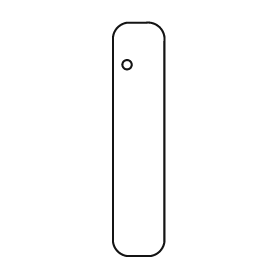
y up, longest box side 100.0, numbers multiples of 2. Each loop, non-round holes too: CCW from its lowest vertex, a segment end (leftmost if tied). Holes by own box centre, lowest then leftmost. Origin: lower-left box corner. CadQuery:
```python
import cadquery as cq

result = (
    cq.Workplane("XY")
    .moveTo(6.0, 0.0)
    .lineTo(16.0, 0.0)
    .threePointArc((20.0, 2.0), (22.0, 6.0))
    .lineTo(22.0, 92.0)
    .threePointArc((20.0, 98.0), (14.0, 100.0))
    .lineTo(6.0, 100.0)
    .threePointArc((2.0, 98.0), (0.0, 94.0))
    .lineTo(0.0, 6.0)
    .threePointArc((2.0, 2.0), (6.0, 0.0))
    .close()
    .moveTo(6.0, 82.0)
    .circle(2.0)
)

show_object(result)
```